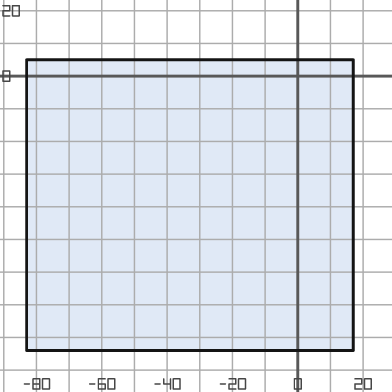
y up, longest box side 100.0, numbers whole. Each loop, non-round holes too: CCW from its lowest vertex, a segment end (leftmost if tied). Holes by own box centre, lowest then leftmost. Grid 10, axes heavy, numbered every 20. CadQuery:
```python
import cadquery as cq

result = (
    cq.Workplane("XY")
    .moveTo(-83.0, -84.0)
    .lineTo(17.0, -84.0)
    .lineTo(17.0, 5.0)
    .lineTo(-83.0, 5.0)
    .close()
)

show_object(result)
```